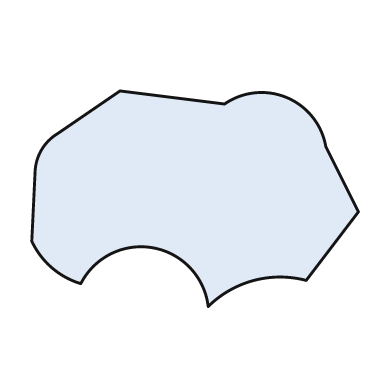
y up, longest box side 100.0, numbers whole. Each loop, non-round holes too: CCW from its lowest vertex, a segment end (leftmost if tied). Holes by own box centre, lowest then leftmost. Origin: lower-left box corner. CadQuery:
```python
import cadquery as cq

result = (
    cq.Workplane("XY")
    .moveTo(54.0, 0.0)
    .threePointArc((68.0, 8.0), (84.0, 8.0))
    .lineTo(100.0, 29.0)
    .lineTo(90.0, 49.0)
    .threePointArc((78.0, 64.0), (59.0, 62.0))
    .lineTo(27.0, 66.0)
    .lineTo(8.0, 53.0)
    .threePointArc((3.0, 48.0), (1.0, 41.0))
    .lineTo(0.0, 20.0)
    .threePointArc((6.0, 12.0), (15.0, 7.0))
    .threePointArc((37.0, 18.0), (54.0, 0.0))
    .close()
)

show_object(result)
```